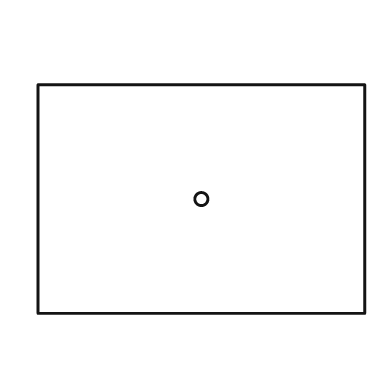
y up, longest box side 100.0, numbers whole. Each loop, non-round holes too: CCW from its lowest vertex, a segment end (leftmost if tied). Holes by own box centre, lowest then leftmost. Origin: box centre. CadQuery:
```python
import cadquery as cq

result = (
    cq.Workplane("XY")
    .moveTo(-50.0, -35.0)
    .lineTo(50.0, -35.0)
    .lineTo(50.0, 35.0)
    .lineTo(-50.0, 35.0)
    .close()
    .moveTo(0.0, 0.0)
    .circle(2.0)
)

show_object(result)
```